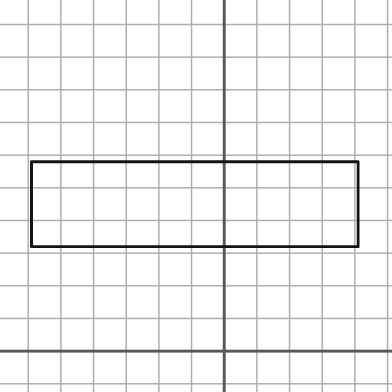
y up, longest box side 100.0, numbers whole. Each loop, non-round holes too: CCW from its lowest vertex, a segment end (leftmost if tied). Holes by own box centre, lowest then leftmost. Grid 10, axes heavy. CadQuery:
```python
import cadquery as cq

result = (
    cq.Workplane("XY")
    .moveTo(-59.0, 32.0)
    .lineTo(41.0, 32.0)
    .lineTo(41.0, 58.0)
    .lineTo(-59.0, 58.0)
    .close()
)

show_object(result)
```